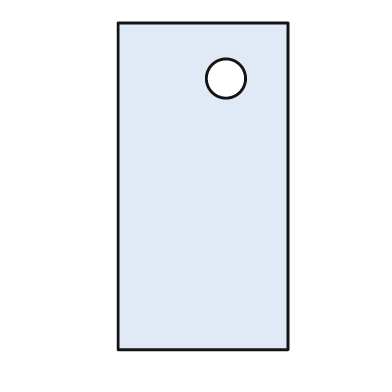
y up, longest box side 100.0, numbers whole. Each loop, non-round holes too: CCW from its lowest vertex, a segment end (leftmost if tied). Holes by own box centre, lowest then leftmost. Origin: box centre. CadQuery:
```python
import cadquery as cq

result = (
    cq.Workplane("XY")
    .moveTo(-26.0, -50.0)
    .lineTo(26.0, -50.0)
    .lineTo(26.0, 50.0)
    .lineTo(-26.0, 50.0)
    .close()
    .moveTo(7.0, 33.0)
    .circle(6.0)
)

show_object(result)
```